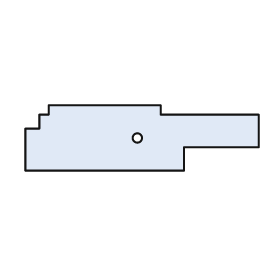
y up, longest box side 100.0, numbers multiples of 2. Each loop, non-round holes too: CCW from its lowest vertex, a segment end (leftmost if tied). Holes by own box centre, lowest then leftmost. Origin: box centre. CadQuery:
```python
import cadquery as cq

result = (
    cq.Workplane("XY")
    .moveTo(-50.0, -14.0)
    .lineTo(18.0, -14.0)
    .lineTo(18.0, -4.0)
    .lineTo(50.0, -4.0)
    .lineTo(50.0, 10.0)
    .lineTo(8.0, 10.0)
    .lineTo(8.0, 14.0)
    .lineTo(-40.0, 14.0)
    .lineTo(-40.0, 10.0)
    .lineTo(-44.0, 10.0)
    .lineTo(-44.0, 4.0)
    .lineTo(-50.0, 4.0)
    .close()
    .moveTo(-2.0, 0.0)
    .circle(2.0)
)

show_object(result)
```